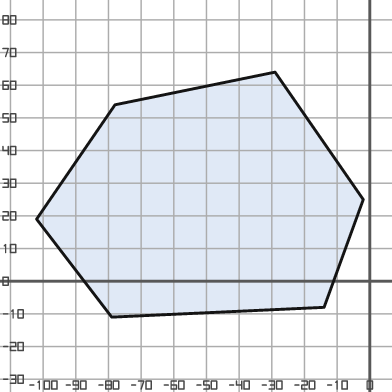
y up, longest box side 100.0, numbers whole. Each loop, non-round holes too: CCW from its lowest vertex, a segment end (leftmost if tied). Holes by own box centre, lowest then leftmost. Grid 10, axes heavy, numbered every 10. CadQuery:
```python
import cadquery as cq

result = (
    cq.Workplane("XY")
    .moveTo(-79.0, -11.0)
    .lineTo(-14.0, -8.0)
    .lineTo(-2.0, 25.0)
    .lineTo(-29.0, 64.0)
    .lineTo(-78.0, 54.0)
    .lineTo(-102.0, 19.0)
    .close()
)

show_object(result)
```